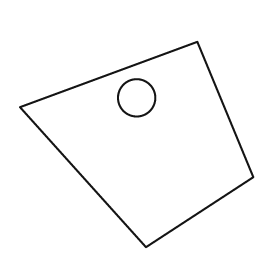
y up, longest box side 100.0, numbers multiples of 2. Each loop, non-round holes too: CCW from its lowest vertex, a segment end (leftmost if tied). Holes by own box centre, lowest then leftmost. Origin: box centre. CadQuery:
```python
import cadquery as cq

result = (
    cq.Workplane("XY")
    .moveTo(4.0, -44.0)
    .lineTo(50.0, -14.0)
    .lineTo(26.0, 44.0)
    .lineTo(-50.0, 16.0)
    .close()
    .moveTo(0.0, 20.0)
    .circle(8.0)
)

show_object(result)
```